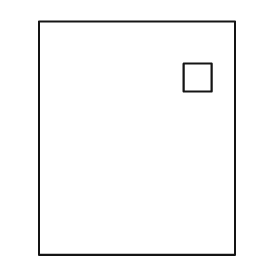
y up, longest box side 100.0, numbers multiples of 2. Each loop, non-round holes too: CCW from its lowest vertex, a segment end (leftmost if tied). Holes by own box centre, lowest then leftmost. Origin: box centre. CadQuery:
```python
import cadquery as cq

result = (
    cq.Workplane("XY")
    .moveTo(-42.0, -50.0)
    .lineTo(42.0, -50.0)
    .lineTo(42.0, 50.0)
    .lineTo(-42.0, 50.0)
    .close()
    .moveTo(20.0, 20.0)
    .lineTo(32.0, 20.0)
    .lineTo(32.0, 32.0)
    .lineTo(20.0, 32.0)
    .close()
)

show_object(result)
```